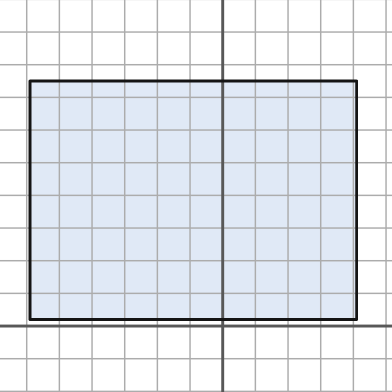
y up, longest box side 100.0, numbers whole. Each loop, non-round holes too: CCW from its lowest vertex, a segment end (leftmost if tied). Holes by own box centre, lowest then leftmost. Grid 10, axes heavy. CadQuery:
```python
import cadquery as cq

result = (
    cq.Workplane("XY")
    .moveTo(-59.0, 2.0)
    .lineTo(41.0, 2.0)
    .lineTo(41.0, 75.0)
    .lineTo(-59.0, 75.0)
    .close()
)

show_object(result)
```